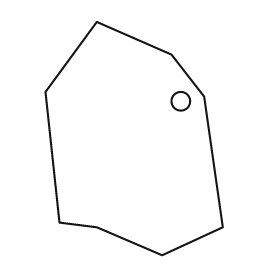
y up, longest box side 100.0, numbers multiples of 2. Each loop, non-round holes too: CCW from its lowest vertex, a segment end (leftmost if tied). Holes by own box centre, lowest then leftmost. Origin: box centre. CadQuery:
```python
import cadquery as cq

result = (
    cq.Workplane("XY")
    .moveTo(12.0, -50.0)
    .lineTo(38.0, -38.0)
    .lineTo(30.0, 18.0)
    .lineTo(16.0, 36.0)
    .lineTo(-16.0, 50.0)
    .lineTo(-38.0, 20.0)
    .lineTo(-32.0, -36.0)
    .lineTo(-16.0, -38.0)
    .close()
    .moveTo(20.0, 16.0)
    .circle(4.0)
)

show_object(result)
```